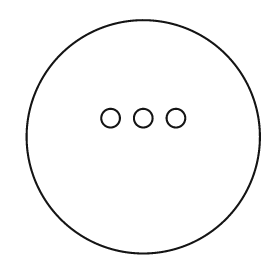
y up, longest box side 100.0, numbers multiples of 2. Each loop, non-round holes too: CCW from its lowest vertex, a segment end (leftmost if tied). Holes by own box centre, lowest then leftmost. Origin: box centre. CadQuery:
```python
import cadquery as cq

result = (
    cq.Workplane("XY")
    .moveTo(0.0, 0.0)
    .circle(50.0)
    .moveTo(-14.0, 8.0)
    .circle(4.0)
    .moveTo(0.0, 8.0)
    .circle(4.0)
    .moveTo(14.0, 8.0)
    .circle(4.0)
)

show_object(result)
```